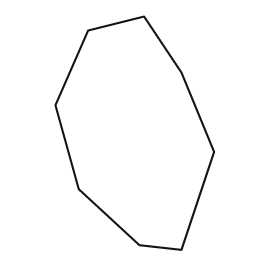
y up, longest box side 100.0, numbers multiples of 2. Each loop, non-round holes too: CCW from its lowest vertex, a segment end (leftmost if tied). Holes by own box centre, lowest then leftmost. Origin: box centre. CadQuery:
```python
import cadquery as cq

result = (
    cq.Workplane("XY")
    .moveTo(20.0, -50.0)
    .lineTo(34.0, -8.0)
    .lineTo(20.0, 26.0)
    .lineTo(4.0, 50.0)
    .lineTo(-20.0, 44.0)
    .lineTo(-34.0, 12.0)
    .lineTo(-24.0, -24.0)
    .lineTo(2.0, -48.0)
    .close()
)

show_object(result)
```